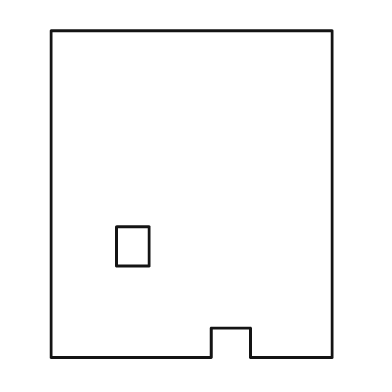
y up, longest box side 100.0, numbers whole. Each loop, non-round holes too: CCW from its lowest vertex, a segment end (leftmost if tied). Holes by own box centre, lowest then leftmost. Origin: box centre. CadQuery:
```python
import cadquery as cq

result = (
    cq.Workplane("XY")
    .moveTo(-43.0, -50.0)
    .lineTo(6.0, -50.0)
    .lineTo(6.0, -41.0)
    .lineTo(18.0, -41.0)
    .lineTo(18.0, -50.0)
    .lineTo(43.0, -50.0)
    .lineTo(43.0, 50.0)
    .lineTo(-43.0, 50.0)
    .close()
    .moveTo(-23.0, -22.0)
    .lineTo(-13.0, -22.0)
    .lineTo(-13.0, -10.0)
    .lineTo(-23.0, -10.0)
    .close()
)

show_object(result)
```